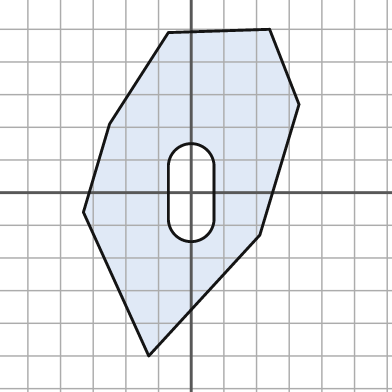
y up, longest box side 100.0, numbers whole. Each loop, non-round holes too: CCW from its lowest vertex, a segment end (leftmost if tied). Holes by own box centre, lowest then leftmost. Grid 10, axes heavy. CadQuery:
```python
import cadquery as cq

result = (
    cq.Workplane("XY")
    .moveTo(-13.0, -50.0)
    .lineTo(21.0, -13.0)
    .lineTo(33.0, 27.0)
    .lineTo(24.0, 50.0)
    .lineTo(-7.0, 49.0)
    .lineTo(-25.0, 21.0)
    .lineTo(-33.0, -6.0)
    .close()
    .moveTo(-7.0, -8.0)
    .threePointArc((0.0, -15.0), (7.0, -8.0))
    .lineTo(7.0, 8.0)
    .threePointArc((0.0, 15.0), (-7.0, 8.0))
    .close()
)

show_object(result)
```